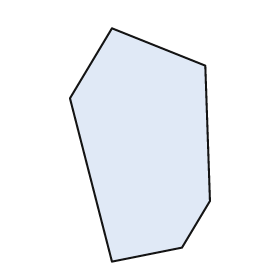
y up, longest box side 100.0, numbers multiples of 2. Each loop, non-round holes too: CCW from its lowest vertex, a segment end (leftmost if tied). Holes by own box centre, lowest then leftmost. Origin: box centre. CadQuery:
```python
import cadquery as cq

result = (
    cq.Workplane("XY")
    .moveTo(-12.0, -50.0)
    .lineTo(18.0, -44.0)
    .lineTo(30.0, -24.0)
    .lineTo(28.0, 34.0)
    .lineTo(-12.0, 50.0)
    .lineTo(-30.0, 20.0)
    .close()
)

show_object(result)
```